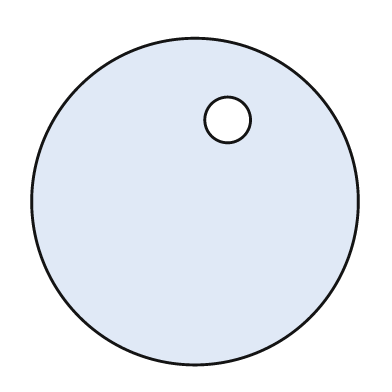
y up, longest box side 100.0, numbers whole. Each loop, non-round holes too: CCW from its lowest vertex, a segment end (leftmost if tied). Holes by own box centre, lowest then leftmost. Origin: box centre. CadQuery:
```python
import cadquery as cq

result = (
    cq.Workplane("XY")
    .moveTo(0.0, 0.0)
    .circle(50.0)
    .moveTo(10.0, 25.0)
    .circle(7.0)
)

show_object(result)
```